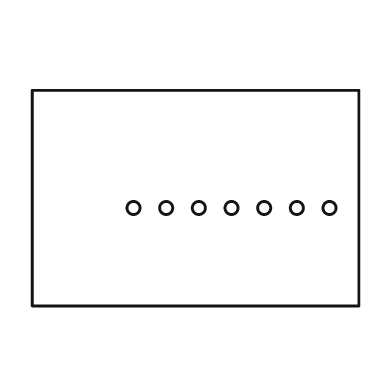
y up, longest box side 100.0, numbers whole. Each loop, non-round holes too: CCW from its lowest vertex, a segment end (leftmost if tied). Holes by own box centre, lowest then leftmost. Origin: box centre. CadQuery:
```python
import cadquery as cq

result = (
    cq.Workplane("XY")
    .moveTo(-50.0, -33.0)
    .lineTo(50.0, -33.0)
    .lineTo(50.0, 33.0)
    .lineTo(-50.0, 33.0)
    .close()
    .moveTo(-19.0, -3.0)
    .circle(2.0)
    .moveTo(-9.0, -3.0)
    .circle(2.0)
    .moveTo(1.0, -3.0)
    .circle(2.0)
    .moveTo(11.0, -3.0)
    .circle(2.0)
    .moveTo(21.0, -3.0)
    .circle(2.0)
    .moveTo(31.0, -3.0)
    .circle(2.0)
    .moveTo(41.0, -3.0)
    .circle(2.0)
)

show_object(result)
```